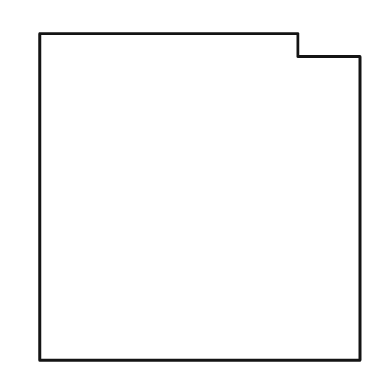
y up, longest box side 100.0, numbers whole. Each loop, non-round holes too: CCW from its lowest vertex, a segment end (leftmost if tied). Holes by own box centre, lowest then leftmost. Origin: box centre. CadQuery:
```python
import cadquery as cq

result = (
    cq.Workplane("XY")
    .moveTo(-49.0, -50.0)
    .lineTo(49.0, -50.0)
    .lineTo(49.0, 43.0)
    .lineTo(30.0, 43.0)
    .lineTo(30.0, 50.0)
    .lineTo(-49.0, 50.0)
    .close()
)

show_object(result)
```